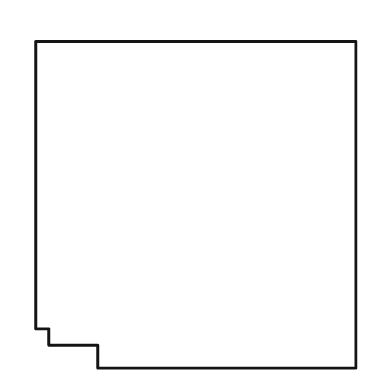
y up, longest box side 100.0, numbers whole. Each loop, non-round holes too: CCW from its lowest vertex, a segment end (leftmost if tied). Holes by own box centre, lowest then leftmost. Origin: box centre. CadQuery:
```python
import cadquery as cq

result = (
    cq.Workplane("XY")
    .moveTo(-30.0, -50.0)
    .lineTo(49.0, -50.0)
    .lineTo(49.0, 50.0)
    .lineTo(-49.0, 50.0)
    .lineTo(-49.0, -38.0)
    .lineTo(-45.0, -38.0)
    .lineTo(-45.0, -43.0)
    .lineTo(-30.0, -43.0)
    .close()
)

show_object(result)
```